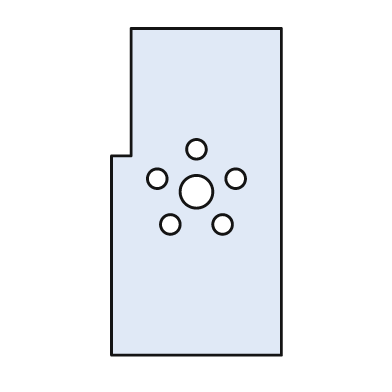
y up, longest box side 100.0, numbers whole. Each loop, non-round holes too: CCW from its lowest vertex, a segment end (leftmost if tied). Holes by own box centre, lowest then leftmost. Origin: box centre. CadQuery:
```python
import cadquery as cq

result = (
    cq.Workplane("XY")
    .moveTo(-26.0, -50.0)
    .lineTo(26.0, -50.0)
    .lineTo(26.0, 50.0)
    .lineTo(-20.0, 50.0)
    .lineTo(-20.0, 11.0)
    .lineTo(-26.0, 11.0)
    .close()
    .moveTo(-8.0, -10.0)
    .circle(3.0)
    .moveTo(8.0, -10.0)
    .circle(3.0)
    .moveTo(0.0, 0.0)
    .circle(5.0)
    .moveTo(-12.0, 4.0)
    .circle(3.0)
    .moveTo(12.0, 4.0)
    .circle(3.0)
    .moveTo(0.0, 13.0)
    .circle(3.0)
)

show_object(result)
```